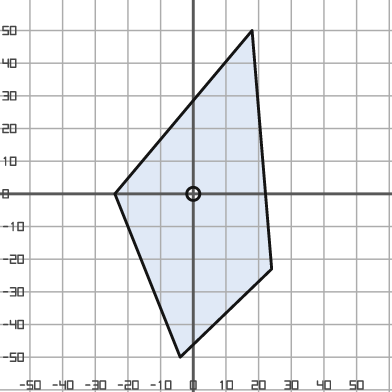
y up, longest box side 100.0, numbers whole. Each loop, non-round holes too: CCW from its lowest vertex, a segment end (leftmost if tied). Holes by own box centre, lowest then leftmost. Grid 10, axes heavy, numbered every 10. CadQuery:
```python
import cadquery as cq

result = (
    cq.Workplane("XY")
    .moveTo(-4.0, -50.0)
    .lineTo(24.0, -23.0)
    .lineTo(18.0, 50.0)
    .lineTo(-24.0, 0.0)
    .close()
    .moveTo(0.0, 0.0)
    .circle(2.0)
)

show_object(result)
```